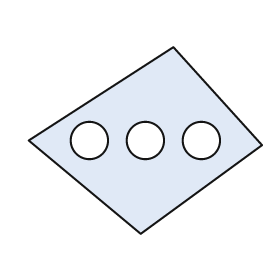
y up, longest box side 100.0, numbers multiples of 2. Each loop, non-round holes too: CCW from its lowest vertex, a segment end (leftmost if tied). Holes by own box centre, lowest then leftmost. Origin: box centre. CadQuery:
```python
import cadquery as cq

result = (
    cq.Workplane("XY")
    .moveTo(-2.0, -40.0)
    .lineTo(50.0, -2.0)
    .lineTo(12.0, 40.0)
    .lineTo(-50.0, 0.0)
    .close()
    .moveTo(-24.0, 0.0)
    .circle(8.0)
    .moveTo(0.0, 0.0)
    .circle(8.0)
    .moveTo(24.0, 0.0)
    .circle(8.0)
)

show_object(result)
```